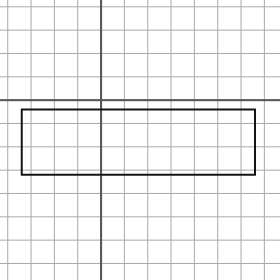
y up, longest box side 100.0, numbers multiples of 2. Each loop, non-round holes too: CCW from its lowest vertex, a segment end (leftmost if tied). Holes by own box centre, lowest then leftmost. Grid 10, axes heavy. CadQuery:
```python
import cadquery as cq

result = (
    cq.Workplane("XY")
    .moveTo(-34.0, -32.0)
    .lineTo(66.0, -32.0)
    .lineTo(66.0, -4.0)
    .lineTo(-34.0, -4.0)
    .close()
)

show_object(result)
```